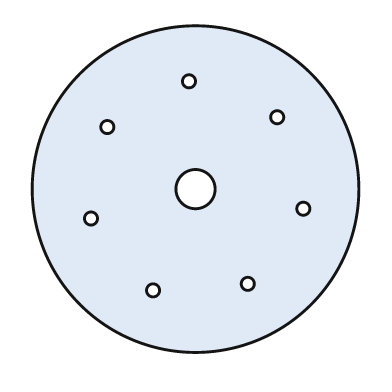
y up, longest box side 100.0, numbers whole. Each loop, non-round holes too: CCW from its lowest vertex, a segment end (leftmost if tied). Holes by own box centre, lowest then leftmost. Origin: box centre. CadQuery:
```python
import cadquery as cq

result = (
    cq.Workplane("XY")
    .moveTo(0.0, 0.0)
    .circle(50.0)
    .moveTo(-13.0, -31.0)
    .circle(2.0)
    .moveTo(16.0, -29.0)
    .circle(2.0)
    .moveTo(-32.0, -9.0)
    .circle(2.0)
    .moveTo(33.0, -6.0)
    .circle(2.0)
    .moveTo(0.0, 0.0)
    .circle(6.0)
    .moveTo(-27.0, 19.0)
    .circle(2.0)
    .moveTo(25.0, 22.0)
    .circle(2.0)
    .moveTo(-2.0, 33.0)
    .circle(2.0)
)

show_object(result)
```